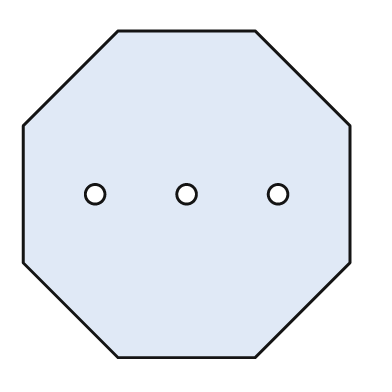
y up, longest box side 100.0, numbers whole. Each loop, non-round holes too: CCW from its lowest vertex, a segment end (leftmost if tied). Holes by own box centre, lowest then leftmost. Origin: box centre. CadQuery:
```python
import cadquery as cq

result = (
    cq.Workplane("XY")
    .moveTo(-21.0, -50.0)
    .lineTo(21.0, -50.0)
    .lineTo(50.0, -21.0)
    .lineTo(50.0, 21.0)
    .lineTo(21.0, 50.0)
    .lineTo(-21.0, 50.0)
    .lineTo(-50.0, 21.0)
    .lineTo(-50.0, -21.0)
    .close()
    .moveTo(-28.0, 0.0)
    .circle(3.0)
    .moveTo(0.0, 0.0)
    .circle(3.0)
    .moveTo(28.0, 0.0)
    .circle(3.0)
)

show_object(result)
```